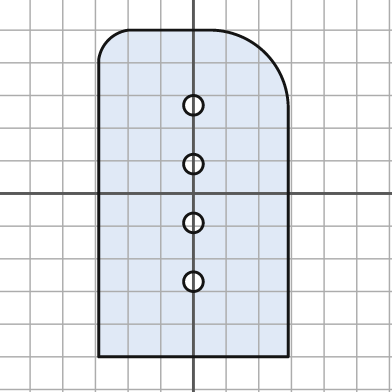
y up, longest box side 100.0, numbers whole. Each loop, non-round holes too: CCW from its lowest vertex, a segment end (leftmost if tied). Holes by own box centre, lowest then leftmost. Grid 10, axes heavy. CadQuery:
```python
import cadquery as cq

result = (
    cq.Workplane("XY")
    .moveTo(-29.0, -50.0)
    .lineTo(29.0, -50.0)
    .lineTo(29.0, 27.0)
    .threePointArc((22.0, 43.0), (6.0, 50.0))
    .lineTo(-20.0, 50.0)
    .threePointArc((-26.0, 47.0), (-29.0, 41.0))
    .close()
    .moveTo(0.0, -27.0)
    .circle(3.0)
    .moveTo(0.0, -9.0)
    .circle(3.0)
    .moveTo(0.0, 9.0)
    .circle(3.0)
    .moveTo(0.0, 27.0)
    .circle(3.0)
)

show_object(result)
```